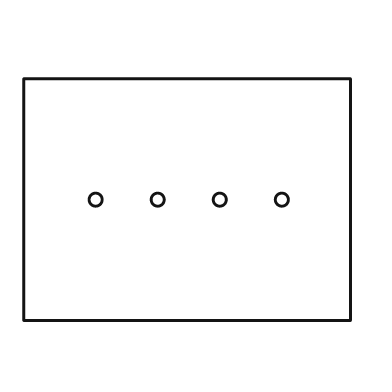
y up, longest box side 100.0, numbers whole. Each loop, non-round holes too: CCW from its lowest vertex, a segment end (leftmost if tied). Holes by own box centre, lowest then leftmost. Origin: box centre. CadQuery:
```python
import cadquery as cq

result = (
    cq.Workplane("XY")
    .moveTo(-50.0, -37.0)
    .lineTo(50.0, -37.0)
    .lineTo(50.0, 37.0)
    .lineTo(-50.0, 37.0)
    .close()
    .moveTo(-28.0, 0.0)
    .circle(2.0)
    .moveTo(-9.0, 0.0)
    .circle(2.0)
    .moveTo(10.0, 0.0)
    .circle(2.0)
    .moveTo(29.0, 0.0)
    .circle(2.0)
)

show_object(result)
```